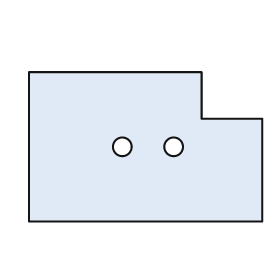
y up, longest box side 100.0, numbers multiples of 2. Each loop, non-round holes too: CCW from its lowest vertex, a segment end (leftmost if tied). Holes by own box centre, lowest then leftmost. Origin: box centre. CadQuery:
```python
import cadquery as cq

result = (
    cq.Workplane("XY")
    .moveTo(-50.0, -32.0)
    .lineTo(50.0, -32.0)
    .lineTo(50.0, 12.0)
    .lineTo(24.0, 12.0)
    .lineTo(24.0, 32.0)
    .lineTo(-50.0, 32.0)
    .close()
    .moveTo(-10.0, 0.0)
    .circle(4.0)
    .moveTo(12.0, 0.0)
    .circle(4.0)
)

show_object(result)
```